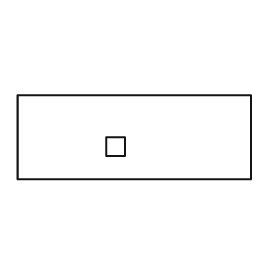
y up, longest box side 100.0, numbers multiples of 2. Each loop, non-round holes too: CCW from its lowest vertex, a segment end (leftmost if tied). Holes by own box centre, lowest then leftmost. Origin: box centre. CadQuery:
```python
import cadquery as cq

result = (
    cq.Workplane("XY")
    .moveTo(-50.0, -18.0)
    .lineTo(50.0, -18.0)
    .lineTo(50.0, 18.0)
    .lineTo(-50.0, 18.0)
    .close()
    .moveTo(-12.0, -8.0)
    .lineTo(-4.0, -8.0)
    .lineTo(-4.0, 0.0)
    .lineTo(-12.0, 0.0)
    .close()
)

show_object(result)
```